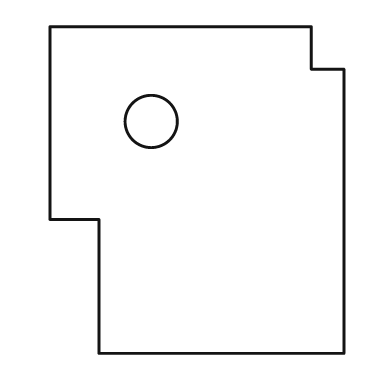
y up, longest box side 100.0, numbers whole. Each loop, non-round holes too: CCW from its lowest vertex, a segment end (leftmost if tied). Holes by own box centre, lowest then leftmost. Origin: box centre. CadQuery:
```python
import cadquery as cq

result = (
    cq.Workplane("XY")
    .moveTo(-30.0, -50.0)
    .lineTo(45.0, -50.0)
    .lineTo(45.0, 37.0)
    .lineTo(35.0, 37.0)
    .lineTo(35.0, 50.0)
    .lineTo(-45.0, 50.0)
    .lineTo(-45.0, -9.0)
    .lineTo(-30.0, -9.0)
    .close()
    .moveTo(-14.0, 21.0)
    .circle(8.0)
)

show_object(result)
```